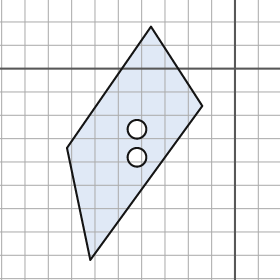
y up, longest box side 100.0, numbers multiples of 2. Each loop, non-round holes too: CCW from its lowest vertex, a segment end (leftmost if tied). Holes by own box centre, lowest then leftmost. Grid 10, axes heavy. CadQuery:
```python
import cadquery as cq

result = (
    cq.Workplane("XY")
    .moveTo(-62.0, -82.0)
    .lineTo(-14.0, -16.0)
    .lineTo(-36.0, 18.0)
    .lineTo(-72.0, -34.0)
    .close()
    .moveTo(-42.0, -38.0)
    .circle(4.0)
    .moveTo(-42.0, -26.0)
    .circle(4.0)
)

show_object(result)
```